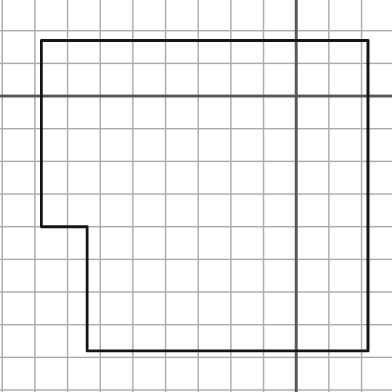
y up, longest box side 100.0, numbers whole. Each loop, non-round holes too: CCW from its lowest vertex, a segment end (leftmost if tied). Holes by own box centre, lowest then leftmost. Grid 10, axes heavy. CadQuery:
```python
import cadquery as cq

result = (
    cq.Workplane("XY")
    .moveTo(-64.0, -78.0)
    .lineTo(22.0, -78.0)
    .lineTo(22.0, 17.0)
    .lineTo(-78.0, 17.0)
    .lineTo(-78.0, -40.0)
    .lineTo(-64.0, -40.0)
    .close()
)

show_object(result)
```